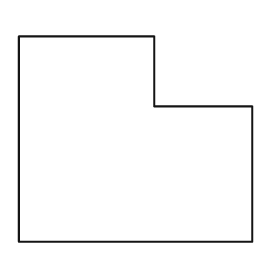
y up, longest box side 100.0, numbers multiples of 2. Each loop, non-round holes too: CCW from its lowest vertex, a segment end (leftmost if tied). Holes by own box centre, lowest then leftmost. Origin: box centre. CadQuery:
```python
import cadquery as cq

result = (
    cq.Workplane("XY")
    .moveTo(-50.0, -44.0)
    .lineTo(50.0, -44.0)
    .lineTo(50.0, 14.0)
    .lineTo(8.0, 14.0)
    .lineTo(8.0, 44.0)
    .lineTo(-50.0, 44.0)
    .close()
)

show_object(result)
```